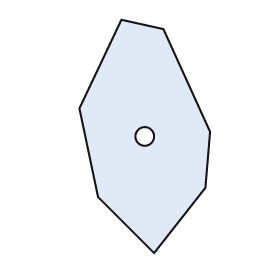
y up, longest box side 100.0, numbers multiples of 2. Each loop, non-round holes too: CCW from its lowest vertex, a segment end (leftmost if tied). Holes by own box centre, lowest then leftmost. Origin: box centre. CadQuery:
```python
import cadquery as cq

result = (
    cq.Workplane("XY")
    .moveTo(4.0, -50.0)
    .lineTo(26.0, -22.0)
    .lineTo(28.0, 2.0)
    .lineTo(8.0, 46.0)
    .lineTo(-10.0, 50.0)
    .lineTo(-28.0, 12.0)
    .lineTo(-20.0, -26.0)
    .close()
    .moveTo(0.0, 0.0)
    .circle(4.0)
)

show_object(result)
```